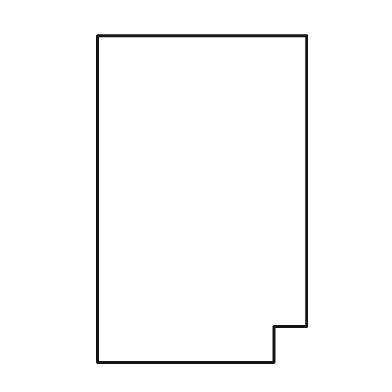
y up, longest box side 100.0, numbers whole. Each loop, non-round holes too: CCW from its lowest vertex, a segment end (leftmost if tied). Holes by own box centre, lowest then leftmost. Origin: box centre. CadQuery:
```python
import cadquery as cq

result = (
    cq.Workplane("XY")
    .moveTo(-32.0, -50.0)
    .lineTo(22.0, -50.0)
    .lineTo(22.0, -39.0)
    .lineTo(32.0, -39.0)
    .lineTo(32.0, 50.0)
    .lineTo(-32.0, 50.0)
    .close()
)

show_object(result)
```